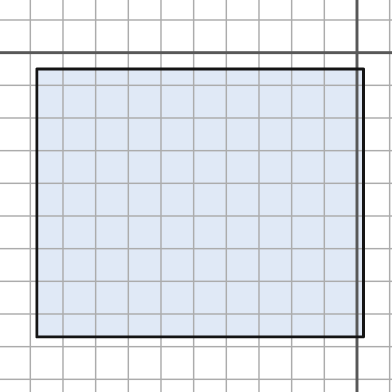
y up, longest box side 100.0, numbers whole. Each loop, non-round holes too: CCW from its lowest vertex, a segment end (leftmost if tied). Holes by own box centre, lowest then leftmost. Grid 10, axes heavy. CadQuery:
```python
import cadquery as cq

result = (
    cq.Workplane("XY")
    .moveTo(-98.0, -87.0)
    .lineTo(2.0, -87.0)
    .lineTo(2.0, -5.0)
    .lineTo(-98.0, -5.0)
    .close()
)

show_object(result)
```